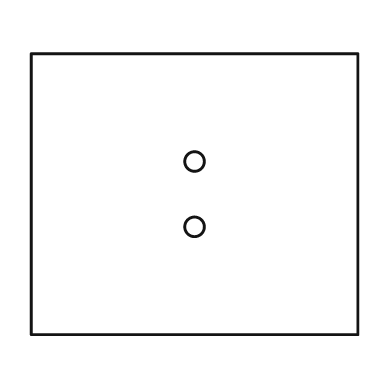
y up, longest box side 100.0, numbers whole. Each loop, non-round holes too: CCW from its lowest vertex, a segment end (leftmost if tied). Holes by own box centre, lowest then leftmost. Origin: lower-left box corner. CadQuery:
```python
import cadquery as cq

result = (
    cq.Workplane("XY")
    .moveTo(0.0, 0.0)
    .lineTo(100.0, 0.0)
    .lineTo(100.0, 86.0)
    .lineTo(0.0, 86.0)
    .close()
    .moveTo(50.0, 33.0)
    .circle(3.0)
    .moveTo(50.0, 53.0)
    .circle(3.0)
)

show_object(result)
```